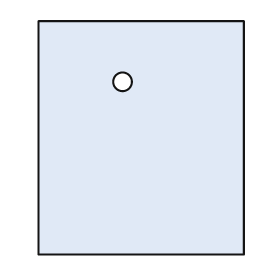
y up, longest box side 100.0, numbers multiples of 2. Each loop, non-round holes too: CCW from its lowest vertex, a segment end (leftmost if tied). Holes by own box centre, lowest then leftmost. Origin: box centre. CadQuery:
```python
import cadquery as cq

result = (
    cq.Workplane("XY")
    .moveTo(-44.0, -50.0)
    .lineTo(44.0, -50.0)
    .lineTo(44.0, 50.0)
    .lineTo(-44.0, 50.0)
    .close()
    .moveTo(-8.0, 24.0)
    .circle(4.0)
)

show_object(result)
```